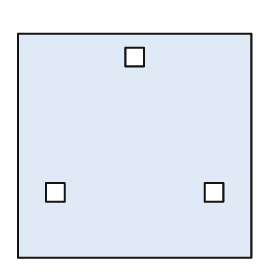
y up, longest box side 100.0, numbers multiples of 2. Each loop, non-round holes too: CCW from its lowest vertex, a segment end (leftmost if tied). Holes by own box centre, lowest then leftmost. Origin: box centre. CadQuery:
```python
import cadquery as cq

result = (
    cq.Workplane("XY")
    .moveTo(-50.0, -48.0)
    .lineTo(50.0, -48.0)
    .lineTo(50.0, 48.0)
    .lineTo(-50.0, 48.0)
    .close()
    .moveTo(-38.0, -24.0)
    .lineTo(-30.0, -24.0)
    .lineTo(-30.0, -16.0)
    .lineTo(-38.0, -16.0)
    .close()
    .moveTo(30.0, -24.0)
    .lineTo(38.0, -24.0)
    .lineTo(38.0, -16.0)
    .lineTo(30.0, -16.0)
    .close()
    .moveTo(-4.0, 34.0)
    .lineTo(4.0, 34.0)
    .lineTo(4.0, 42.0)
    .lineTo(-4.0, 42.0)
    .close()
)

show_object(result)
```